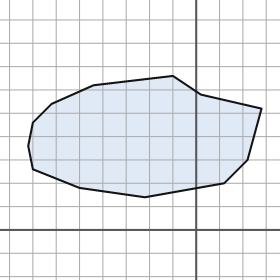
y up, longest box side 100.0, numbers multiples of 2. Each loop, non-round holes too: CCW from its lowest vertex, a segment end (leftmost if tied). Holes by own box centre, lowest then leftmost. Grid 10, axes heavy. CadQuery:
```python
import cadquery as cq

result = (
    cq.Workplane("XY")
    .moveTo(-22.0, 14.0)
    .lineTo(12.0, 20.0)
    .lineTo(22.0, 30.0)
    .lineTo(28.0, 52.0)
    .lineTo(2.0, 58.0)
    .lineTo(-10.0, 66.0)
    .lineTo(-44.0, 62.0)
    .lineTo(-62.0, 54.0)
    .lineTo(-70.0, 46.0)
    .lineTo(-72.0, 36.0)
    .lineTo(-70.0, 26.0)
    .lineTo(-50.0, 18.0)
    .close()
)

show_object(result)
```